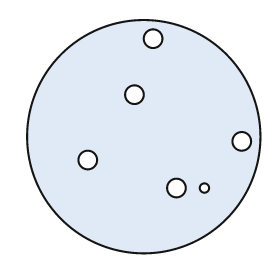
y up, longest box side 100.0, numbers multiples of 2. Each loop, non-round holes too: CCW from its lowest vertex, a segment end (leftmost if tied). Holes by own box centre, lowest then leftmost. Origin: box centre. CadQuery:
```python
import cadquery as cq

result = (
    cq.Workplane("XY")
    .moveTo(0.0, 0.0)
    .circle(50.0)
    .moveTo(14.0, -22.0)
    .circle(4.0)
    .moveTo(26.0, -22.0)
    .circle(2.0)
    .moveTo(-24.0, -10.0)
    .circle(4.0)
    .moveTo(42.0, -2.0)
    .circle(4.0)
    .moveTo(-4.0, 18.0)
    .circle(4.0)
    .moveTo(4.0, 42.0)
    .circle(4.0)
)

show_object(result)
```